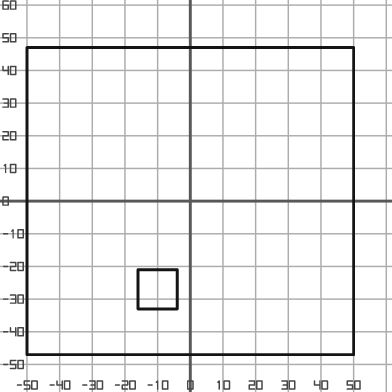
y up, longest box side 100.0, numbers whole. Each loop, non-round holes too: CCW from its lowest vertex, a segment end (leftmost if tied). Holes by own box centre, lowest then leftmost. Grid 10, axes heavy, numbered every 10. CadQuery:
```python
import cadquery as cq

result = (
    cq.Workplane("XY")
    .moveTo(-50.0, -47.0)
    .lineTo(50.0, -47.0)
    .lineTo(50.0, 47.0)
    .lineTo(-50.0, 47.0)
    .close()
    .moveTo(-16.0, -33.0)
    .lineTo(-4.0, -33.0)
    .lineTo(-4.0, -21.0)
    .lineTo(-16.0, -21.0)
    .close()
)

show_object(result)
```